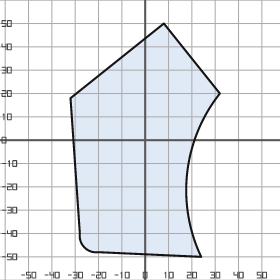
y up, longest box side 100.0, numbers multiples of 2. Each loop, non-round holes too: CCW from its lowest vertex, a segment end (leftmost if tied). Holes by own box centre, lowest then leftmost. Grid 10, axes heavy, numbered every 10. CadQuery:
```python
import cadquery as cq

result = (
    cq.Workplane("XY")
    .moveTo(24.0, -50.0)
    .threePointArc((18.0, -14.0), (32.0, 20.0))
    .lineTo(8.0, 50.0)
    .lineTo(-32.0, 18.0)
    .lineTo(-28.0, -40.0)
    .threePointArc((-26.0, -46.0), (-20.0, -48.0))
    .close()
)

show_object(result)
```